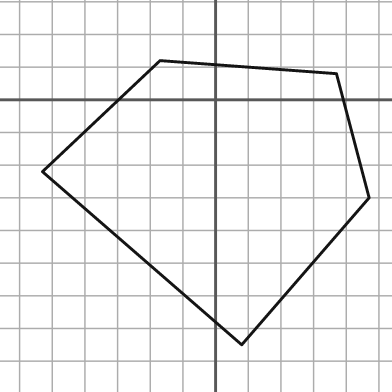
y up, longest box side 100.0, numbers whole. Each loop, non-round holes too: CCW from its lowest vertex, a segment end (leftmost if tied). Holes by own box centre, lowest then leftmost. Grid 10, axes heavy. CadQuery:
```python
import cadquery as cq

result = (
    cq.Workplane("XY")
    .moveTo(8.0, -75.0)
    .lineTo(47.0, -30.0)
    .lineTo(37.0, 8.0)
    .lineTo(-17.0, 12.0)
    .lineTo(-53.0, -22.0)
    .close()
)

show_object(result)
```